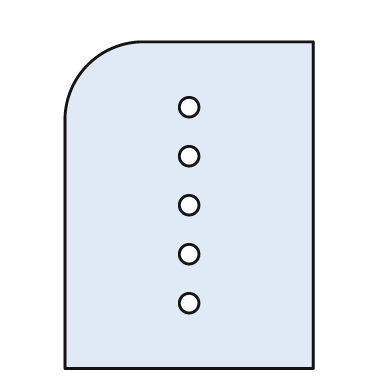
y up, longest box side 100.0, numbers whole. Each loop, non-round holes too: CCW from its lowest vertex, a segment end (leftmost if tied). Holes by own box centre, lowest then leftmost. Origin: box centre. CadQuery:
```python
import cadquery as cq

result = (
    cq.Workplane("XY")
    .moveTo(-38.0, -50.0)
    .lineTo(38.0, -50.0)
    .lineTo(38.0, 50.0)
    .lineTo(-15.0, 50.0)
    .threePointArc((-31.0, 43.0), (-38.0, 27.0))
    .close()
    .moveTo(0.0, -30.0)
    .circle(3.0)
    .moveTo(0.0, -15.0)
    .circle(3.0)
    .moveTo(0.0, 0.0)
    .circle(3.0)
    .moveTo(0.0, 15.0)
    .circle(3.0)
    .moveTo(0.0, 30.0)
    .circle(3.0)
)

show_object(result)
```